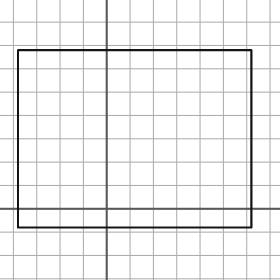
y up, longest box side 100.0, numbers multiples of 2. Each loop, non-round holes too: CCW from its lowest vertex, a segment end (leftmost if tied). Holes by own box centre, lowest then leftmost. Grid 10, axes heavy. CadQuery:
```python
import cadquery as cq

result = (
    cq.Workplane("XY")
    .moveTo(-38.0, -8.0)
    .lineTo(62.0, -8.0)
    .lineTo(62.0, 68.0)
    .lineTo(-38.0, 68.0)
    .close()
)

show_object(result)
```